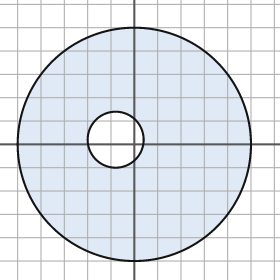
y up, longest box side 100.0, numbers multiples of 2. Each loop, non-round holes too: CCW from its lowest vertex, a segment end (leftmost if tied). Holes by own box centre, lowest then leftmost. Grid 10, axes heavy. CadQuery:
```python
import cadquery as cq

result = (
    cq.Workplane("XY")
    .moveTo(0.0, 0.0)
    .circle(50.0)
    .moveTo(-8.0, 2.0)
    .circle(12.0)
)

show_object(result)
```